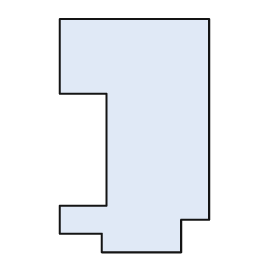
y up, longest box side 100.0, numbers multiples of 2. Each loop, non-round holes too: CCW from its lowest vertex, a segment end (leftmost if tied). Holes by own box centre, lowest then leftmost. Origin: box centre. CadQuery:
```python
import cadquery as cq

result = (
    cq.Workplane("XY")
    .moveTo(-14.0, -50.0)
    .lineTo(20.0, -50.0)
    .lineTo(20.0, -36.0)
    .lineTo(32.0, -36.0)
    .lineTo(32.0, 50.0)
    .lineTo(-32.0, 50.0)
    .lineTo(-32.0, 18.0)
    .lineTo(-12.0, 18.0)
    .lineTo(-12.0, -30.0)
    .lineTo(-32.0, -30.0)
    .lineTo(-32.0, -42.0)
    .lineTo(-14.0, -42.0)
    .close()
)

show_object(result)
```